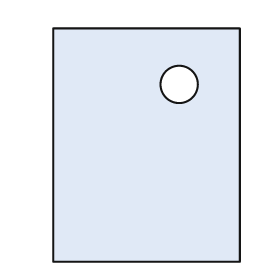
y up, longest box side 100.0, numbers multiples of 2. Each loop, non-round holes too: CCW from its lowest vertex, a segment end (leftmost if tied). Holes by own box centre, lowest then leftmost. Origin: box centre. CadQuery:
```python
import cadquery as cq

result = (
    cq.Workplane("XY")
    .moveTo(-40.0, -50.0)
    .lineTo(40.0, -50.0)
    .lineTo(40.0, 50.0)
    .lineTo(-40.0, 50.0)
    .close()
    .moveTo(14.0, 26.0)
    .circle(8.0)
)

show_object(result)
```